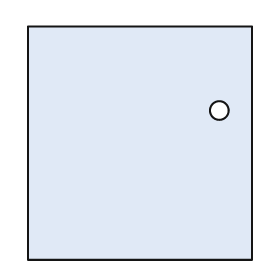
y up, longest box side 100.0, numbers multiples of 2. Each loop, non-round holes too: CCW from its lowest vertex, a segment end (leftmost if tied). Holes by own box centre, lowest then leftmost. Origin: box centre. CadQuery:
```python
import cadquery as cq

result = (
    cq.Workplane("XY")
    .moveTo(-48.0, -50.0)
    .lineTo(48.0, -50.0)
    .lineTo(48.0, 50.0)
    .lineTo(-48.0, 50.0)
    .close()
    .moveTo(34.0, 14.0)
    .circle(4.0)
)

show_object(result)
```